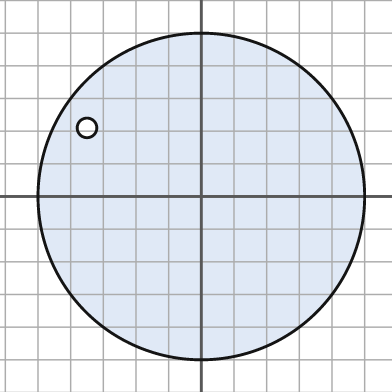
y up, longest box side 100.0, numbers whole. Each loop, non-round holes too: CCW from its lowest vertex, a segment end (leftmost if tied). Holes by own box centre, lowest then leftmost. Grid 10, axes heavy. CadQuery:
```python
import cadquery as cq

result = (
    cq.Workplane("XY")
    .moveTo(0.0, 0.0)
    .circle(50.0)
    .moveTo(-35.0, 21.0)
    .circle(3.0)
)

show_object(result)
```